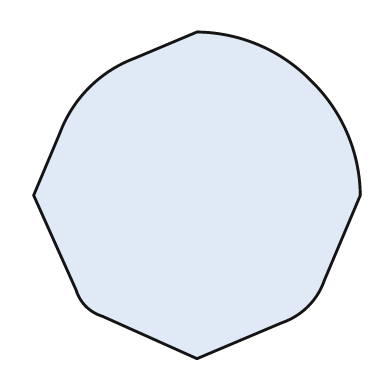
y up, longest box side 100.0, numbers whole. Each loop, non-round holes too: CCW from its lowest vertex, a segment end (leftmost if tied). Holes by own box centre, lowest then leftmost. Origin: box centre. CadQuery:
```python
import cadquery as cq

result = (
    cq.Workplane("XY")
    .moveTo(0.0, -50.0)
    .lineTo(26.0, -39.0)
    .threePointArc((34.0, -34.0), (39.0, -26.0))
    .lineTo(50.0, 0.0)
    .threePointArc((46.0, 19.0), (35.0, 35.0))
    .threePointArc((19.0, 46.0), (0.0, 50.0))
    .lineTo(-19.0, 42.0)
    .threePointArc((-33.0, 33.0), (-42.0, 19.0))
    .lineTo(-50.0, 0.0)
    .lineTo(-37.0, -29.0)
    .threePointArc((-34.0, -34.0), (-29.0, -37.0))
    .close()
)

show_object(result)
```